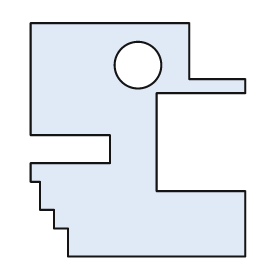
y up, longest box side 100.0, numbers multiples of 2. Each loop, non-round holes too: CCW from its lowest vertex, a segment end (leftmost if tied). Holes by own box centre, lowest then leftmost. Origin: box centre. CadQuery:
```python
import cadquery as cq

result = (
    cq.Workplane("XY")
    .moveTo(-30.0, -50.0)
    .lineTo(46.0, -50.0)
    .lineTo(46.0, -22.0)
    .lineTo(8.0, -22.0)
    .lineTo(8.0, 20.0)
    .lineTo(46.0, 20.0)
    .lineTo(46.0, 26.0)
    .lineTo(22.0, 26.0)
    .lineTo(22.0, 50.0)
    .lineTo(-46.0, 50.0)
    .lineTo(-46.0, 2.0)
    .lineTo(-12.0, 2.0)
    .lineTo(-12.0, -10.0)
    .lineTo(-46.0, -10.0)
    .lineTo(-46.0, -18.0)
    .lineTo(-42.0, -18.0)
    .lineTo(-42.0, -30.0)
    .lineTo(-36.0, -30.0)
    .lineTo(-36.0, -38.0)
    .lineTo(-30.0, -38.0)
    .close()
    .moveTo(0.0, 32.0)
    .circle(10.0)
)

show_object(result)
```